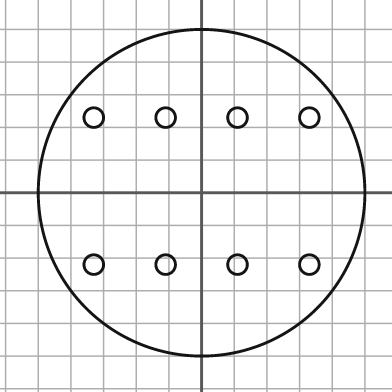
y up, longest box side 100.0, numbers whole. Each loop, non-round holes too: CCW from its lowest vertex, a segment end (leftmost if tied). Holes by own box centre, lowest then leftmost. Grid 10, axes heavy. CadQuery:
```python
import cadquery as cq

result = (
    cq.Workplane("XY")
    .moveTo(0.0, 0.0)
    .circle(50.0)
    .moveTo(-33.0, -22.0)
    .circle(3.0)
    .moveTo(-11.0, -22.0)
    .circle(3.0)
    .moveTo(11.0, -22.0)
    .circle(3.0)
    .moveTo(33.0, -22.0)
    .circle(3.0)
    .moveTo(-33.0, 23.0)
    .circle(3.0)
    .moveTo(-11.0, 23.0)
    .circle(3.0)
    .moveTo(11.0, 23.0)
    .circle(3.0)
    .moveTo(33.0, 23.0)
    .circle(3.0)
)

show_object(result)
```